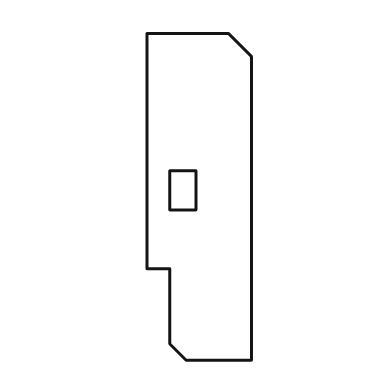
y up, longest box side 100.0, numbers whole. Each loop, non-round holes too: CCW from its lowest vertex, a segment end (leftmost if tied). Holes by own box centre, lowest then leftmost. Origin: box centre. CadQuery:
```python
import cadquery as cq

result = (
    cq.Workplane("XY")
    .moveTo(-4.0, -50.0)
    .lineTo(16.0, -50.0)
    .lineTo(16.0, 43.0)
    .lineTo(9.0, 50.0)
    .lineTo(-16.0, 50.0)
    .lineTo(-16.0, -22.0)
    .lineTo(-9.0, -22.0)
    .lineTo(-9.0, -45.0)
    .close()
    .moveTo(-9.0, -4.0)
    .lineTo(-1.0, -4.0)
    .lineTo(-1.0, 8.0)
    .lineTo(-9.0, 8.0)
    .close()
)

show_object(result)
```